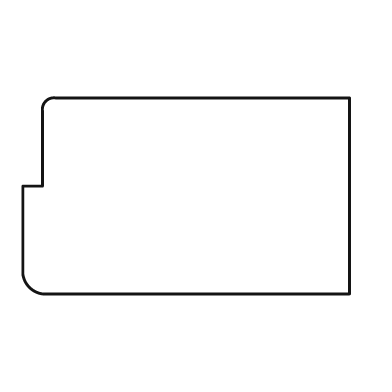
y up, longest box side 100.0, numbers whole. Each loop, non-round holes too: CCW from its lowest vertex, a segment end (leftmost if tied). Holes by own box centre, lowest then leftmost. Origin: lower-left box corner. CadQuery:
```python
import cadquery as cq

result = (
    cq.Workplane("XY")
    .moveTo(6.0, 0.0)
    .lineTo(100.0, 0.0)
    .lineTo(100.0, 60.0)
    .lineTo(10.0, 60.0)
    .threePointArc((7.0, 59.0), (6.0, 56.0))
    .lineTo(6.0, 33.0)
    .lineTo(0.0, 33.0)
    .lineTo(0.0, 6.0)
    .threePointArc((2.0, 2.0), (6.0, 0.0))
    .close()
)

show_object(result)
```